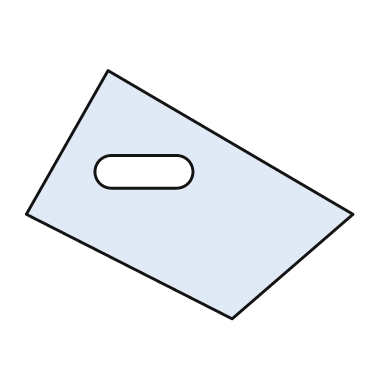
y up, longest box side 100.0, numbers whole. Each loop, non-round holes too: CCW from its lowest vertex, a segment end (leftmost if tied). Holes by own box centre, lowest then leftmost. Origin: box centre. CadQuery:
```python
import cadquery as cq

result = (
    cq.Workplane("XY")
    .moveTo(13.0, -38.0)
    .lineTo(50.0, -6.0)
    .lineTo(-25.0, 38.0)
    .lineTo(-50.0, -6.0)
    .close()
    .moveTo(-24.0, 2.0)
    .lineTo(-4.0, 2.0)
    .threePointArc((1.0, 7.0), (-4.0, 12.0))
    .lineTo(-24.0, 12.0)
    .threePointArc((-29.0, 7.0), (-24.0, 2.0))
    .close()
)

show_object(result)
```